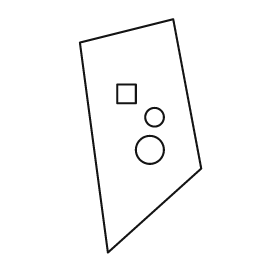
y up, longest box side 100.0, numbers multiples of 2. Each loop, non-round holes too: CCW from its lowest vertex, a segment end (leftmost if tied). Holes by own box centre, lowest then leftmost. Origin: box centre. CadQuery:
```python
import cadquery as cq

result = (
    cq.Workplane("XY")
    .moveTo(-14.0, -50.0)
    .lineTo(26.0, -14.0)
    .lineTo(14.0, 50.0)
    .lineTo(-26.0, 40.0)
    .close()
    .moveTo(4.0, -6.0)
    .circle(6.0)
    .moveTo(6.0, 8.0)
    .circle(4.0)
    .moveTo(-10.0, 14.0)
    .lineTo(-2.0, 14.0)
    .lineTo(-2.0, 22.0)
    .lineTo(-10.0, 22.0)
    .close()
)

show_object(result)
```